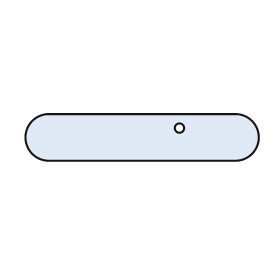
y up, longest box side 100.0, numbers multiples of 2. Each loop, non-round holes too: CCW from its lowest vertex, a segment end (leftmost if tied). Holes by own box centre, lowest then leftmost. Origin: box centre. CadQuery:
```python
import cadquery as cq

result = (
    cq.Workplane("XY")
    .moveTo(-40.0, -10.0)
    .lineTo(40.0, -10.0)
    .threePointArc((50.0, 0.0), (40.0, 10.0))
    .lineTo(-40.0, 10.0)
    .threePointArc((-50.0, 0.0), (-40.0, -10.0))
    .close()
    .moveTo(16.0, 4.0)
    .circle(2.0)
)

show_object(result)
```